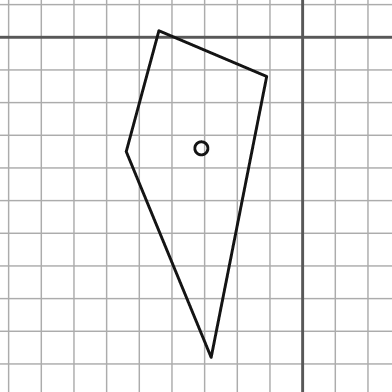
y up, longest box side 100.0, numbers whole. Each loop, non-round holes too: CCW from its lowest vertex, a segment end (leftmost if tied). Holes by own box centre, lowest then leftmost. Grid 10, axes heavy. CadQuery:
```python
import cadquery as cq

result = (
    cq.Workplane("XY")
    .moveTo(-28.0, -98.0)
    .lineTo(-11.0, -12.0)
    .lineTo(-44.0, 2.0)
    .lineTo(-54.0, -35.0)
    .close()
    .moveTo(-31.0, -34.0)
    .circle(2.0)
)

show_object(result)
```